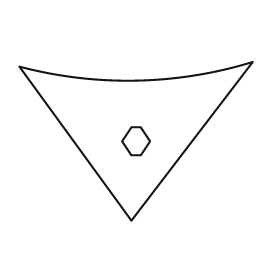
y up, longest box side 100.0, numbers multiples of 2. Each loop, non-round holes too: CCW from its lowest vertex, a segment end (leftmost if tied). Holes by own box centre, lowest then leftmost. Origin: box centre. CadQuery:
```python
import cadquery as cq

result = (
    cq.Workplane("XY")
    .moveTo(-2.0, -34.0)
    .lineTo(50.0, 34.0)
    .threePointArc((0.0, 26.0), (-50.0, 32.0))
    .close()
    .moveTo(-2.0, -6.0)
    .lineTo(2.0, -6.0)
    .lineTo(6.0, 0.0)
    .lineTo(2.0, 6.0)
    .lineTo(-2.0, 6.0)
    .lineTo(-6.0, 0.0)
    .close()
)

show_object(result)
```